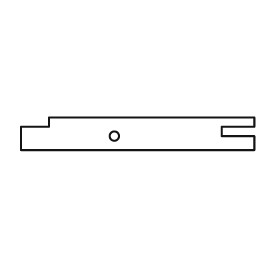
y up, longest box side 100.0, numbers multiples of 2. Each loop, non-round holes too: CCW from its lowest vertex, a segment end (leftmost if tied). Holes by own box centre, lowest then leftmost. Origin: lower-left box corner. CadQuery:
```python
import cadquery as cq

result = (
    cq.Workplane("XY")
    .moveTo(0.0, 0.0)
    .lineTo(100.0, 0.0)
    .lineTo(100.0, 6.0)
    .lineTo(86.0, 6.0)
    .lineTo(86.0, 10.0)
    .lineTo(100.0, 10.0)
    .lineTo(100.0, 14.0)
    .lineTo(12.0, 14.0)
    .lineTo(12.0, 10.0)
    .lineTo(0.0, 10.0)
    .close()
    .moveTo(40.0, 6.0)
    .circle(2.0)
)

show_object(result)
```